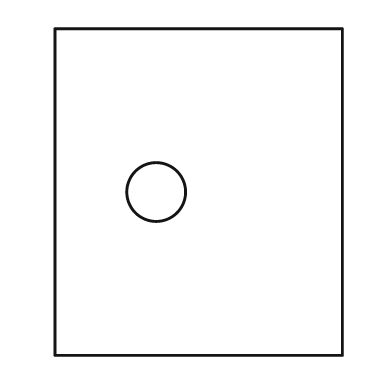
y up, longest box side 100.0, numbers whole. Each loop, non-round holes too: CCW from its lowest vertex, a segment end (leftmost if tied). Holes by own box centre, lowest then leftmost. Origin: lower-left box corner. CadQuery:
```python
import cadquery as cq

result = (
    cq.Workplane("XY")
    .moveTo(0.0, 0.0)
    .lineTo(88.0, 0.0)
    .lineTo(88.0, 100.0)
    .lineTo(0.0, 100.0)
    .close()
    .moveTo(31.0, 50.0)
    .circle(9.0)
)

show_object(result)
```